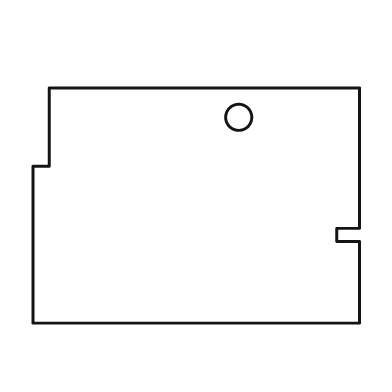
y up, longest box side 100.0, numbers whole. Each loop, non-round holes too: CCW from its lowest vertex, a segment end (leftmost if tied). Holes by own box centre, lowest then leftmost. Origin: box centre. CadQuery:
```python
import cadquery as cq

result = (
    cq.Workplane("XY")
    .moveTo(-50.0, -36.0)
    .lineTo(50.0, -36.0)
    .lineTo(50.0, -11.0)
    .lineTo(43.0, -11.0)
    .lineTo(43.0, -7.0)
    .lineTo(50.0, -7.0)
    .lineTo(50.0, 36.0)
    .lineTo(-45.0, 36.0)
    .lineTo(-45.0, 12.0)
    .lineTo(-50.0, 12.0)
    .close()
    .moveTo(13.0, 27.0)
    .circle(4.0)
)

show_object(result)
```